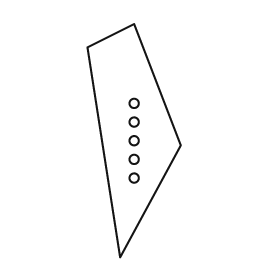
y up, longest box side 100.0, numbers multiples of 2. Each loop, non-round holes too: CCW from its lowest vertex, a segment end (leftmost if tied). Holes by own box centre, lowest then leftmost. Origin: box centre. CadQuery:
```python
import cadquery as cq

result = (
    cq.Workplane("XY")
    .moveTo(-6.0, -50.0)
    .lineTo(20.0, -2.0)
    .lineTo(0.0, 50.0)
    .lineTo(-20.0, 40.0)
    .close()
    .moveTo(0.0, -16.0)
    .circle(2.0)
    .moveTo(0.0, -8.0)
    .circle(2.0)
    .moveTo(0.0, 0.0)
    .circle(2.0)
    .moveTo(0.0, 8.0)
    .circle(2.0)
    .moveTo(0.0, 16.0)
    .circle(2.0)
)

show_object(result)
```